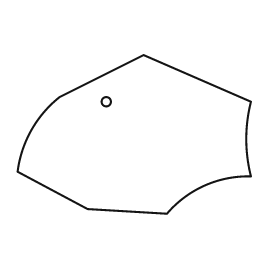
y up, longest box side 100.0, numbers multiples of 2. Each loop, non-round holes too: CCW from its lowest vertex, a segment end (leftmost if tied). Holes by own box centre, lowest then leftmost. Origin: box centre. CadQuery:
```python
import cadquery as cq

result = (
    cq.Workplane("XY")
    .moveTo(14.0, -34.0)
    .threePointArc((30.0, -22.0), (50.0, -18.0))
    .threePointArc((48.0, -2.0), (50.0, 14.0))
    .lineTo(4.0, 34.0)
    .lineTo(-32.0, 16.0)
    .threePointArc((-44.0, 2.0), (-50.0, -16.0))
    .lineTo(-20.0, -32.0)
    .close()
    .moveTo(-12.0, 14.0)
    .circle(2.0)
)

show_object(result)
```